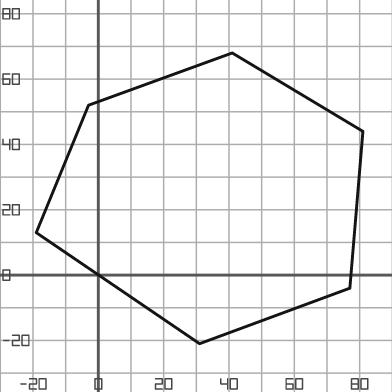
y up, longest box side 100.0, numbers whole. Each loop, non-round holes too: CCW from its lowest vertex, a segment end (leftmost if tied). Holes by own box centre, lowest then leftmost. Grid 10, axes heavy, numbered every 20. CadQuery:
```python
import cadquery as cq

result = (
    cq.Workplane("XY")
    .moveTo(31.0, -21.0)
    .lineTo(77.0, -4.0)
    .lineTo(81.0, 44.0)
    .lineTo(41.0, 68.0)
    .lineTo(-3.0, 52.0)
    .lineTo(-19.0, 13.0)
    .close()
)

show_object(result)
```